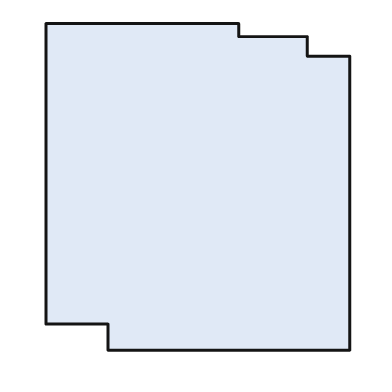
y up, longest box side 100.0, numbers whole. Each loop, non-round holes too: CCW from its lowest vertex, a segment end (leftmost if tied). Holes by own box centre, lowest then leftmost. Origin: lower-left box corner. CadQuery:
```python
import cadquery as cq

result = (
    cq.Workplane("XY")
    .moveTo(19.0, 0.0)
    .lineTo(93.0, 0.0)
    .lineTo(93.0, 90.0)
    .lineTo(80.0, 90.0)
    .lineTo(80.0, 96.0)
    .lineTo(59.0, 96.0)
    .lineTo(59.0, 100.0)
    .lineTo(0.0, 100.0)
    .lineTo(0.0, 8.0)
    .lineTo(19.0, 8.0)
    .close()
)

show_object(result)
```